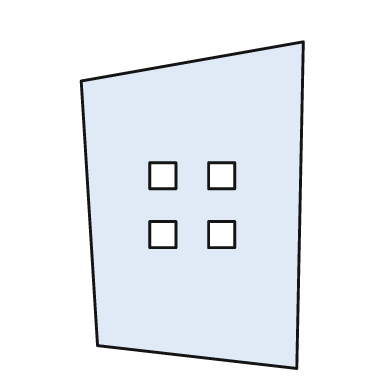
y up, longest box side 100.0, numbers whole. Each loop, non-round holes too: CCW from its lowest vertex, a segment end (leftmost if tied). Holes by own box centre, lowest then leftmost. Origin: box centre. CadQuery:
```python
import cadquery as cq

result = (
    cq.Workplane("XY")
    .moveTo(32.0, -50.0)
    .lineTo(34.0, 50.0)
    .lineTo(-34.0, 38.0)
    .lineTo(-29.0, -43.0)
    .close()
    .moveTo(-13.0, -13.0)
    .lineTo(-5.0, -13.0)
    .lineTo(-5.0, -5.0)
    .lineTo(-13.0, -5.0)
    .close()
    .moveTo(5.0, -13.0)
    .lineTo(13.0, -13.0)
    .lineTo(13.0, -5.0)
    .lineTo(5.0, -5.0)
    .close()
    .moveTo(-13.0, 5.0)
    .lineTo(-5.0, 5.0)
    .lineTo(-5.0, 13.0)
    .lineTo(-13.0, 13.0)
    .close()
    .moveTo(5.0, 5.0)
    .lineTo(13.0, 5.0)
    .lineTo(13.0, 13.0)
    .lineTo(5.0, 13.0)
    .close()
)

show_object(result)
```